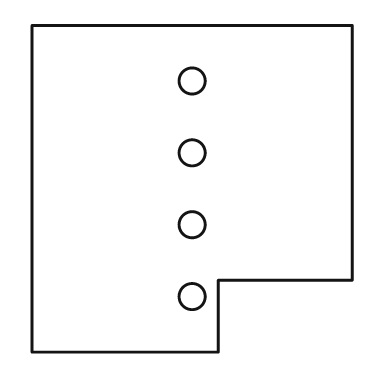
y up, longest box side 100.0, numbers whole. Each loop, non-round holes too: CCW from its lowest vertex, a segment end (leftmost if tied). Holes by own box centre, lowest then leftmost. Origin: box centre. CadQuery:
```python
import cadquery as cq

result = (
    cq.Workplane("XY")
    .moveTo(-49.0, -50.0)
    .lineTo(8.0, -50.0)
    .lineTo(8.0, -28.0)
    .lineTo(49.0, -28.0)
    .lineTo(49.0, 50.0)
    .lineTo(-49.0, 50.0)
    .close()
    .moveTo(0.0, -33.0)
    .circle(4.0)
    .moveTo(0.0, -11.0)
    .circle(4.0)
    .moveTo(0.0, 11.0)
    .circle(4.0)
    .moveTo(0.0, 33.0)
    .circle(4.0)
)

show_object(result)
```